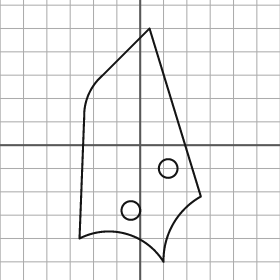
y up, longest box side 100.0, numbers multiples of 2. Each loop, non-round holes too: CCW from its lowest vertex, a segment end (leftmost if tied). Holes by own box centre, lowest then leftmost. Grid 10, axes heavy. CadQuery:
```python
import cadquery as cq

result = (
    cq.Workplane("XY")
    .moveTo(10.0, -50.0)
    .threePointArc((14.0, -34.0), (26.0, -22.0))
    .lineTo(4.0, 50.0)
    .lineTo(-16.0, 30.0)
    .threePointArc((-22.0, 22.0), (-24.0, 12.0))
    .lineTo(-26.0, -40.0)
    .threePointArc((-6.0, -38.0), (10.0, -50.0))
    .close()
    .moveTo(-4.0, -28.0)
    .circle(4.0)
    .moveTo(12.0, -10.0)
    .circle(4.0)
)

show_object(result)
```